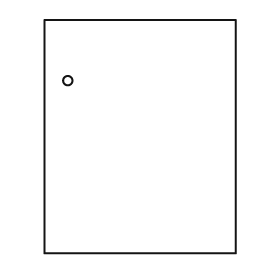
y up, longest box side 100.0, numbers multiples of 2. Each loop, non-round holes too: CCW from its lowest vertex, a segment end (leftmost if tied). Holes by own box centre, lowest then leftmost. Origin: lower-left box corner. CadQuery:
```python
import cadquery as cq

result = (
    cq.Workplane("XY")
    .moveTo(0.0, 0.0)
    .lineTo(82.0, 0.0)
    .lineTo(82.0, 100.0)
    .lineTo(0.0, 100.0)
    .close()
    .moveTo(10.0, 74.0)
    .circle(2.0)
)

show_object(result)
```